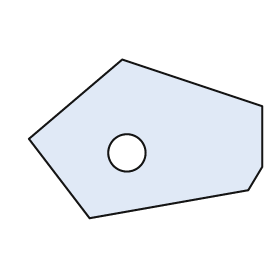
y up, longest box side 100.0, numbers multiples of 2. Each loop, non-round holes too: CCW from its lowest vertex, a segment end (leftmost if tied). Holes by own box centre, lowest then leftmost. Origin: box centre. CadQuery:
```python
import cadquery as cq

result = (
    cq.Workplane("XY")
    .moveTo(-24.0, -34.0)
    .lineTo(44.0, -22.0)
    .lineTo(50.0, -12.0)
    .lineTo(50.0, 14.0)
    .lineTo(-10.0, 34.0)
    .lineTo(-50.0, 0.0)
    .close()
    .moveTo(-8.0, -6.0)
    .circle(8.0)
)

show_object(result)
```